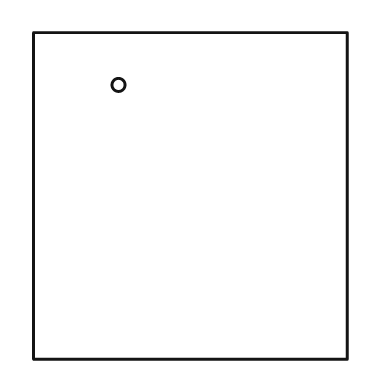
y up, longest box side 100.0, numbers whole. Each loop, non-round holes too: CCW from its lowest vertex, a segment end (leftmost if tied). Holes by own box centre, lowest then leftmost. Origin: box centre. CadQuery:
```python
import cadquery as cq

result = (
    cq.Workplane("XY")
    .moveTo(-48.0, -50.0)
    .lineTo(48.0, -50.0)
    .lineTo(48.0, 50.0)
    .lineTo(-48.0, 50.0)
    .close()
    .moveTo(-22.0, 34.0)
    .circle(2.0)
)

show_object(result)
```